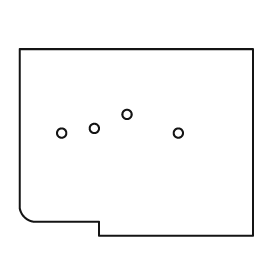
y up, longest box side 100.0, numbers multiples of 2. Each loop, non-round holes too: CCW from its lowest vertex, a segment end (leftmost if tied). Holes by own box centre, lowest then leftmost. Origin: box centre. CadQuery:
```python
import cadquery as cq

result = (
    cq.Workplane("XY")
    .moveTo(-16.0, -40.0)
    .lineTo(50.0, -40.0)
    .lineTo(50.0, 40.0)
    .lineTo(-50.0, 40.0)
    .lineTo(-50.0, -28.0)
    .threePointArc((-48.0, -32.0), (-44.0, -34.0))
    .lineTo(-16.0, -34.0)
    .close()
    .moveTo(-32.0, 4.0)
    .circle(2.0)
    .moveTo(18.0, 4.0)
    .circle(2.0)
    .moveTo(-18.0, 6.0)
    .circle(2.0)
    .moveTo(-4.0, 12.0)
    .circle(2.0)
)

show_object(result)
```